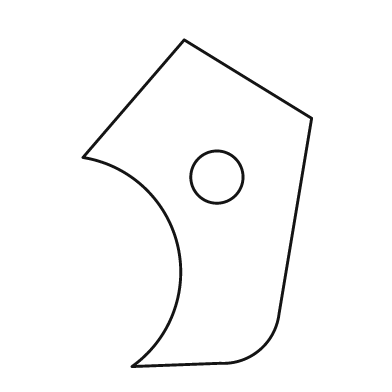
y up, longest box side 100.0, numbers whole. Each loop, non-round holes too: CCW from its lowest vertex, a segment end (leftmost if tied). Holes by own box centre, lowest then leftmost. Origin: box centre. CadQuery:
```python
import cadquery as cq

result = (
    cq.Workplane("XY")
    .moveTo(-20.0, -50.0)
    .lineTo(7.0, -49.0)
    .threePointArc((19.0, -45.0), (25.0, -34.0))
    .lineTo(35.0, 26.0)
    .lineTo(-4.0, 50.0)
    .lineTo(-35.0, 14.0)
    .threePointArc((-6.0, -13.0), (-20.0, -50.0))
    .close()
    .moveTo(6.0, 8.0)
    .circle(8.0)
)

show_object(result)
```